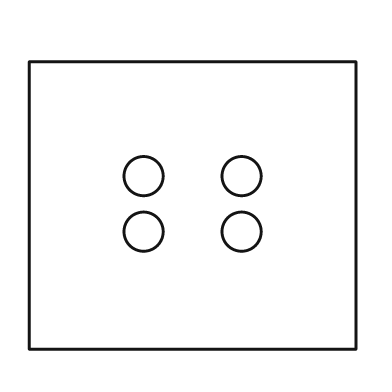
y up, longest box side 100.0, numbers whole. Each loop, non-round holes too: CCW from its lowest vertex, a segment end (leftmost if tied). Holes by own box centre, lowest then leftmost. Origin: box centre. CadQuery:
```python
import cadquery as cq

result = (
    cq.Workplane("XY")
    .moveTo(-50.0, -44.0)
    .lineTo(50.0, -44.0)
    .lineTo(50.0, 44.0)
    .lineTo(-50.0, 44.0)
    .close()
    .moveTo(-15.0, -8.0)
    .circle(6.0)
    .moveTo(15.0, -8.0)
    .circle(6.0)
    .moveTo(-15.0, 9.0)
    .circle(6.0)
    .moveTo(15.0, 9.0)
    .circle(6.0)
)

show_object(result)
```